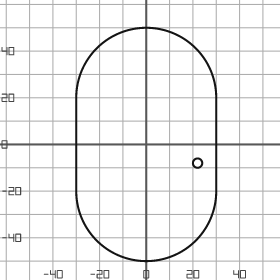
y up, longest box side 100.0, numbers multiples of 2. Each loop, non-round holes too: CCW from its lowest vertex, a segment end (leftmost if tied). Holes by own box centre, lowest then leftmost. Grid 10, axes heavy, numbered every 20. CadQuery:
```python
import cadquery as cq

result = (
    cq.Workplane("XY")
    .moveTo(-30.0, -20.0)
    .threePointArc((0.0, -50.0), (30.0, -20.0))
    .lineTo(30.0, 20.0)
    .threePointArc((0.0, 50.0), (-30.0, 20.0))
    .close()
    .moveTo(22.0, -8.0)
    .circle(2.0)
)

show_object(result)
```